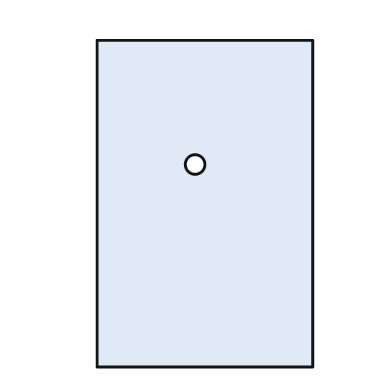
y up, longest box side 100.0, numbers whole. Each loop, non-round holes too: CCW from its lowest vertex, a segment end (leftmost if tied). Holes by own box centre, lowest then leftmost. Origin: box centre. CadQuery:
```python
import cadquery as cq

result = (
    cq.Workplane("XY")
    .moveTo(-33.0, -50.0)
    .lineTo(33.0, -50.0)
    .lineTo(33.0, 50.0)
    .lineTo(-33.0, 50.0)
    .close()
    .moveTo(-3.0, 12.0)
    .circle(3.0)
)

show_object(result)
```